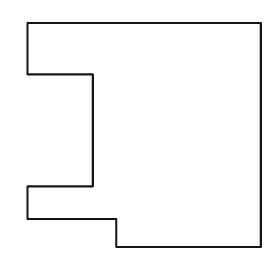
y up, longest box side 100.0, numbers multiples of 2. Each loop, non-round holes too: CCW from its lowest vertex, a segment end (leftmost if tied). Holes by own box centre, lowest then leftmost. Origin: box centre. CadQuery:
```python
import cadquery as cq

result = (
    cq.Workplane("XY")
    .moveTo(-12.0, -48.0)
    .lineTo(50.0, -48.0)
    .lineTo(50.0, 48.0)
    .lineTo(-50.0, 48.0)
    .lineTo(-50.0, 26.0)
    .lineTo(-22.0, 26.0)
    .lineTo(-22.0, -22.0)
    .lineTo(-50.0, -22.0)
    .lineTo(-50.0, -36.0)
    .lineTo(-12.0, -36.0)
    .close()
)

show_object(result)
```